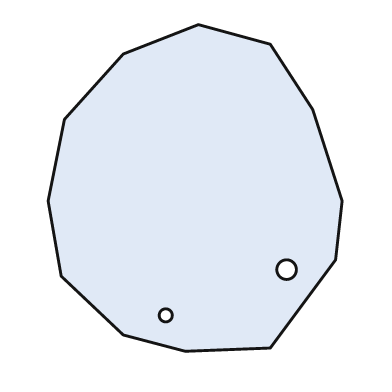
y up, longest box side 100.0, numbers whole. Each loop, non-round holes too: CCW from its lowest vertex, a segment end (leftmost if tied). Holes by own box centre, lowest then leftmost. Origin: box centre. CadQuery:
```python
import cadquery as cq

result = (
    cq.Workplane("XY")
    .moveTo(-3.0, -50.0)
    .lineTo(23.0, -49.0)
    .lineTo(43.0, -22.0)
    .lineTo(45.0, -4.0)
    .lineTo(36.0, 24.0)
    .lineTo(23.0, 44.0)
    .lineTo(1.0, 50.0)
    .lineTo(-22.0, 41.0)
    .lineTo(-40.0, 21.0)
    .lineTo(-45.0, -4.0)
    .lineTo(-41.0, -27.0)
    .lineTo(-22.0, -45.0)
    .close()
    .moveTo(-9.0, -39.0)
    .circle(2.0)
    .moveTo(28.0, -25.0)
    .circle(3.0)
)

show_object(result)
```